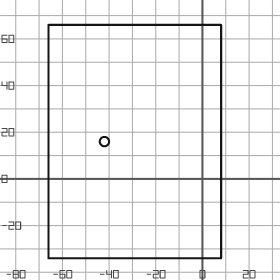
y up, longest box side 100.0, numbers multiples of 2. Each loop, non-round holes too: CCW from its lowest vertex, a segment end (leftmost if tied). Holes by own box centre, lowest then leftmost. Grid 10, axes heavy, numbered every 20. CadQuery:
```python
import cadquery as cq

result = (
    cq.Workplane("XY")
    .moveTo(-66.0, -34.0)
    .lineTo(8.0, -34.0)
    .lineTo(8.0, 66.0)
    .lineTo(-66.0, 66.0)
    .close()
    .moveTo(-42.0, 16.0)
    .circle(2.0)
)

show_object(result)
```